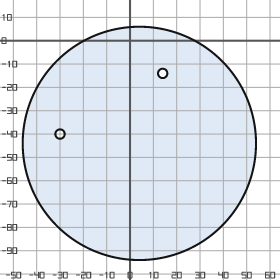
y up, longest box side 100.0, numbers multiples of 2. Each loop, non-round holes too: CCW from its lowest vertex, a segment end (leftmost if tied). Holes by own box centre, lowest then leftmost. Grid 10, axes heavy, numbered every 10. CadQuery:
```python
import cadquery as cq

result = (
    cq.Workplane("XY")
    .moveTo(4.0, -44.0)
    .circle(50.0)
    .moveTo(-30.0, -40.0)
    .circle(2.0)
    .moveTo(14.0, -14.0)
    .circle(2.0)
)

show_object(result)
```